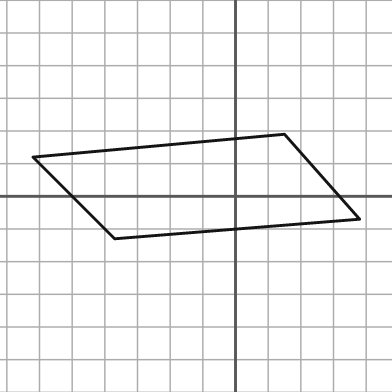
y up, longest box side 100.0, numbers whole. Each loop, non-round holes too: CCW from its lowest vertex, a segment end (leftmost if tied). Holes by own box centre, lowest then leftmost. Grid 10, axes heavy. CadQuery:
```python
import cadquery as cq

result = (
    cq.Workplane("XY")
    .moveTo(-37.0, -13.0)
    .lineTo(38.0, -7.0)
    .lineTo(15.0, 19.0)
    .lineTo(-62.0, 12.0)
    .close()
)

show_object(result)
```